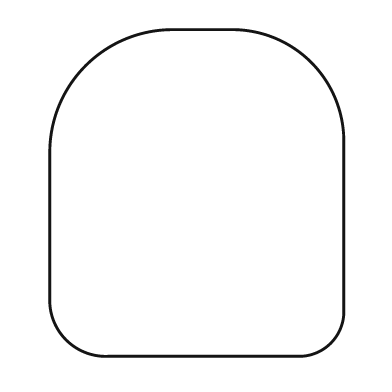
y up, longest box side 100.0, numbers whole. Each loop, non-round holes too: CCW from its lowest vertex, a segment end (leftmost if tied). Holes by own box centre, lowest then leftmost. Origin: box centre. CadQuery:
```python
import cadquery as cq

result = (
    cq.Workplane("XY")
    .moveTo(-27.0, -50.0)
    .lineTo(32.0, -50.0)
    .threePointArc((41.0, -46.0), (45.0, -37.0))
    .lineTo(45.0, 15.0)
    .threePointArc((35.0, 40.0), (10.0, 50.0))
    .lineTo(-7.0, 50.0)
    .threePointArc((-34.0, 39.0), (-45.0, 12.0))
    .lineTo(-45.0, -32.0)
    .threePointArc((-40.0, -45.0), (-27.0, -50.0))
    .close()
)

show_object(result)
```